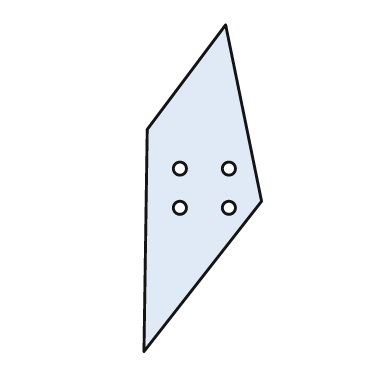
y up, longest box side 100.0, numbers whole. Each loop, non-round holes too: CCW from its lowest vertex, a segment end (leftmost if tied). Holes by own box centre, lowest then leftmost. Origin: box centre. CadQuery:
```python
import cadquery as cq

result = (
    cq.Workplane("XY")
    .moveTo(-18.0, -50.0)
    .lineTo(18.0, -4.0)
    .lineTo(7.0, 50.0)
    .lineTo(-17.0, 18.0)
    .close()
    .moveTo(-7.0, -6.0)
    .circle(2.0)
    .moveTo(8.0, -6.0)
    .circle(2.0)
    .moveTo(-7.0, 6.0)
    .circle(2.0)
    .moveTo(8.0, 6.0)
    .circle(2.0)
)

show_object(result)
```